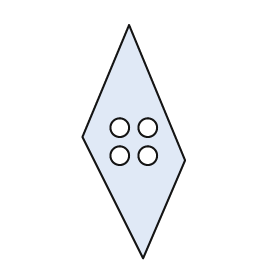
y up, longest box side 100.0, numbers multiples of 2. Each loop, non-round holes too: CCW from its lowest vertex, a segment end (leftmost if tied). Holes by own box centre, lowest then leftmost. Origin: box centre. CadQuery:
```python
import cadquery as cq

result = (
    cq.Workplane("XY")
    .moveTo(4.0, -50.0)
    .lineTo(22.0, -8.0)
    .lineTo(-2.0, 50.0)
    .lineTo(-22.0, 2.0)
    .close()
    .moveTo(-6.0, -6.0)
    .circle(4.0)
    .moveTo(6.0, -6.0)
    .circle(4.0)
    .moveTo(-6.0, 6.0)
    .circle(4.0)
    .moveTo(6.0, 6.0)
    .circle(4.0)
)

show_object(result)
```